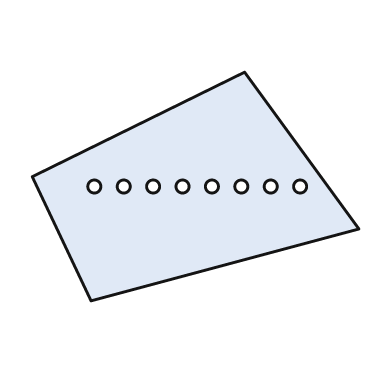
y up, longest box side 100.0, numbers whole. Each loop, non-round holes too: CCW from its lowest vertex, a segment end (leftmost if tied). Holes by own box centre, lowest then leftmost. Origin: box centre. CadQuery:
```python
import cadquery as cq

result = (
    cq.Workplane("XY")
    .moveTo(-32.0, -35.0)
    .lineTo(50.0, -13.0)
    .lineTo(15.0, 35.0)
    .lineTo(-50.0, 3.0)
    .close()
    .moveTo(-31.0, 0.0)
    .circle(2.0)
    .moveTo(-22.0, 0.0)
    .circle(2.0)
    .moveTo(-13.0, 0.0)
    .circle(2.0)
    .moveTo(-4.0, 0.0)
    .circle(2.0)
    .moveTo(5.0, 0.0)
    .circle(2.0)
    .moveTo(14.0, 0.0)
    .circle(2.0)
    .moveTo(23.0, 0.0)
    .circle(2.0)
    .moveTo(32.0, 0.0)
    .circle(2.0)
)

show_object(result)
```